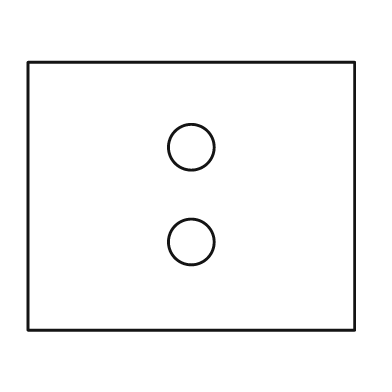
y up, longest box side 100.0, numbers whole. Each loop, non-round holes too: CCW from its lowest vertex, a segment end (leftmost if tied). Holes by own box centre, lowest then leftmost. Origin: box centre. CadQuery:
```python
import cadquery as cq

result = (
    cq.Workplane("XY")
    .moveTo(-50.0, -41.0)
    .lineTo(50.0, -41.0)
    .lineTo(50.0, 41.0)
    .lineTo(-50.0, 41.0)
    .close()
    .moveTo(0.0, -14.0)
    .circle(7.0)
    .moveTo(0.0, 15.0)
    .circle(7.0)
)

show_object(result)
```